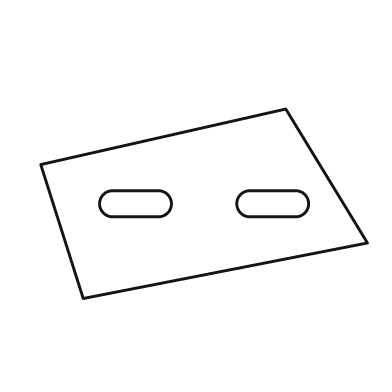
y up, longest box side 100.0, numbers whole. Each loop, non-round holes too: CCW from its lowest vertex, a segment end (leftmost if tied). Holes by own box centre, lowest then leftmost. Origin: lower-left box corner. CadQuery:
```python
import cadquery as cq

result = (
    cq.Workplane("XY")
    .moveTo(13.0, 0.0)
    .lineTo(100.0, 17.0)
    .lineTo(75.0, 58.0)
    .lineTo(0.0, 41.0)
    .close()
    .moveTo(22.0, 25.0)
    .lineTo(36.0, 25.0)
    .threePointArc((40.0, 29.0), (36.0, 33.0))
    .lineTo(22.0, 33.0)
    .threePointArc((18.0, 29.0), (22.0, 25.0))
    .close()
    .moveTo(64.0, 25.0)
    .lineTo(78.0, 25.0)
    .threePointArc((82.0, 29.0), (78.0, 33.0))
    .lineTo(64.0, 33.0)
    .threePointArc((60.0, 29.0), (64.0, 25.0))
    .close()
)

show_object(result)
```